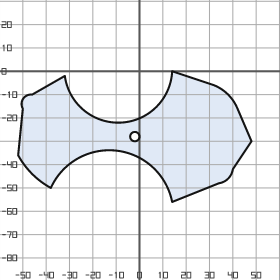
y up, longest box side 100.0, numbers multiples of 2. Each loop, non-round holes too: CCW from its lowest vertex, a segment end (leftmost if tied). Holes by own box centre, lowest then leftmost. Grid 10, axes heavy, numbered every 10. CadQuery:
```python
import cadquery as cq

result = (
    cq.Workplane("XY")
    .moveTo(14.0, -56.0)
    .lineTo(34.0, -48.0)
    .threePointArc((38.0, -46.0), (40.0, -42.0))
    .lineTo(48.0, -30.0)
    .lineTo(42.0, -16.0)
    .threePointArc((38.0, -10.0), (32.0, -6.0))
    .lineTo(14.0, 0.0)
    .threePointArc((-8.0, -22.0), (-32.0, -2.0))
    .lineTo(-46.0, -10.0)
    .threePointArc((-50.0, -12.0), (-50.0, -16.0))
    .lineTo(-52.0, -36.0)
    .threePointArc((-46.0, -44.0), (-38.0, -50.0))
    .threePointArc((-10.0, -34.0), (14.0, -56.0))
    .close()
    .moveTo(-2.0, -28.0)
    .circle(2.0)
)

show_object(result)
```